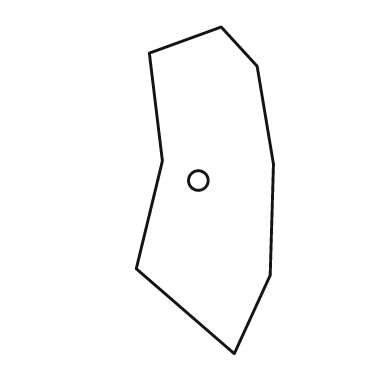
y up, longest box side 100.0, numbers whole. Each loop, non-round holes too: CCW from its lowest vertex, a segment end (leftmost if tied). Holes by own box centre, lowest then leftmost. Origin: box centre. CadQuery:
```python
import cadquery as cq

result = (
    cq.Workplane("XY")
    .moveTo(9.0, -50.0)
    .lineTo(20.0, -26.0)
    .lineTo(21.0, 8.0)
    .lineTo(16.0, 38.0)
    .lineTo(5.0, 50.0)
    .lineTo(-17.0, 42.0)
    .lineTo(-13.0, 9.0)
    .lineTo(-21.0, -24.0)
    .close()
    .moveTo(-2.0, 3.0)
    .circle(3.0)
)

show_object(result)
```